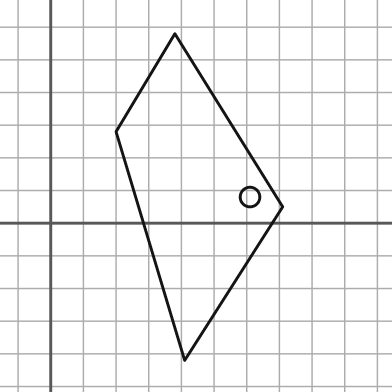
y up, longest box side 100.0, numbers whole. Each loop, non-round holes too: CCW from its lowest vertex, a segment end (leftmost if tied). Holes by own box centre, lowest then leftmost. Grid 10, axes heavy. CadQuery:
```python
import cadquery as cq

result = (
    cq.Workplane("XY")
    .moveTo(41.0, -42.0)
    .lineTo(71.0, 5.0)
    .lineTo(38.0, 58.0)
    .lineTo(20.0, 28.0)
    .close()
    .moveTo(61.0, 8.0)
    .circle(3.0)
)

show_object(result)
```